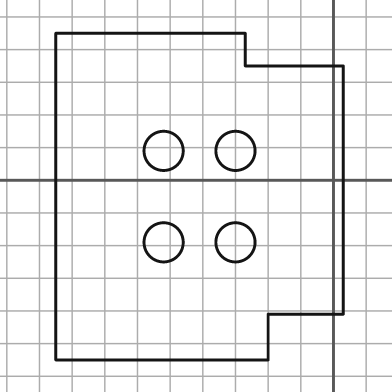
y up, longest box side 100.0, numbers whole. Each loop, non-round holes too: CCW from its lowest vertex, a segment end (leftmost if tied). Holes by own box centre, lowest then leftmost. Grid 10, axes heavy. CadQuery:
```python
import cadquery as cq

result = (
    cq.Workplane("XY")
    .moveTo(-85.0, -55.0)
    .lineTo(-20.0, -55.0)
    .lineTo(-20.0, -41.0)
    .lineTo(3.0, -41.0)
    .lineTo(3.0, 35.0)
    .lineTo(-27.0, 35.0)
    .lineTo(-27.0, 45.0)
    .lineTo(-85.0, 45.0)
    .close()
    .moveTo(-52.0, -19.0)
    .circle(6.0)
    .moveTo(-30.0, -19.0)
    .circle(6.0)
    .moveTo(-52.0, 9.0)
    .circle(6.0)
    .moveTo(-30.0, 9.0)
    .circle(6.0)
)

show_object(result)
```